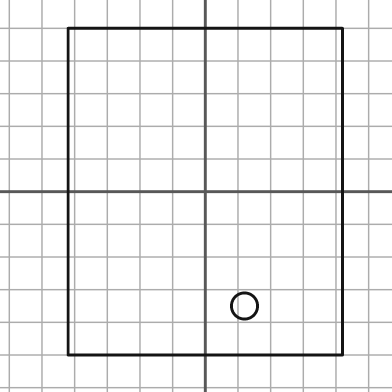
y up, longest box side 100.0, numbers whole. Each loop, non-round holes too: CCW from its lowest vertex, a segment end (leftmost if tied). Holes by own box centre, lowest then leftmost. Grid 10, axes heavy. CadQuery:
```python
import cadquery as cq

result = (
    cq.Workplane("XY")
    .moveTo(-42.0, -50.0)
    .lineTo(42.0, -50.0)
    .lineTo(42.0, 50.0)
    .lineTo(-42.0, 50.0)
    .close()
    .moveTo(12.0, -35.0)
    .circle(4.0)
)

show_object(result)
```